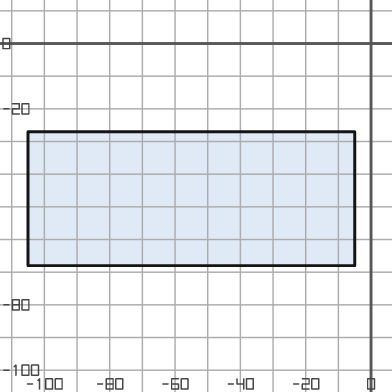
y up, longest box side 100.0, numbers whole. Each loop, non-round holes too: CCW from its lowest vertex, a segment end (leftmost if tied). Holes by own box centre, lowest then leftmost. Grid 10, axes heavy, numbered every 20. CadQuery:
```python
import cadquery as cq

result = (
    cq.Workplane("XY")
    .moveTo(-105.0, -68.0)
    .lineTo(-5.0, -68.0)
    .lineTo(-5.0, -27.0)
    .lineTo(-105.0, -27.0)
    .close()
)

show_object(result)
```